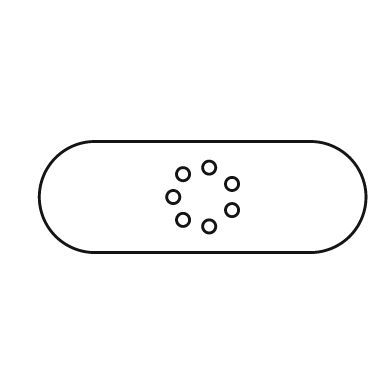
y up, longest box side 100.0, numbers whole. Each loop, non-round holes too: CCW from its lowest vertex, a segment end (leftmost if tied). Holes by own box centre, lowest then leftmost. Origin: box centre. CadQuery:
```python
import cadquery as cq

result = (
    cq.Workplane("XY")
    .moveTo(-33.0, -17.0)
    .lineTo(33.0, -17.0)
    .threePointArc((50.0, 0.0), (33.0, 17.0))
    .lineTo(-33.0, 17.0)
    .threePointArc((-50.0, 0.0), (-33.0, -17.0))
    .close()
    .moveTo(2.0, -9.0)
    .circle(2.0)
    .moveTo(-6.0, -7.0)
    .circle(2.0)
    .moveTo(9.0, -4.0)
    .circle(2.0)
    .moveTo(-9.0, 0.0)
    .circle(2.0)
    .moveTo(9.0, 4.0)
    .circle(2.0)
    .moveTo(-6.0, 7.0)
    .circle(2.0)
    .moveTo(2.0, 9.0)
    .circle(2.0)
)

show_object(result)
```